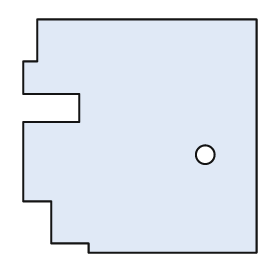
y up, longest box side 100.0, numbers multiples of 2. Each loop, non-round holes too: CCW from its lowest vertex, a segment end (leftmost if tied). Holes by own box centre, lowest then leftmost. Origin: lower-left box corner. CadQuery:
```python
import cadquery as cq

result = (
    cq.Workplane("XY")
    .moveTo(28.0, 0.0)
    .lineTo(100.0, 0.0)
    .lineTo(100.0, 100.0)
    .lineTo(6.0, 100.0)
    .lineTo(6.0, 82.0)
    .lineTo(0.0, 82.0)
    .lineTo(0.0, 68.0)
    .lineTo(24.0, 68.0)
    .lineTo(24.0, 56.0)
    .lineTo(0.0, 56.0)
    .lineTo(0.0, 22.0)
    .lineTo(12.0, 22.0)
    .lineTo(12.0, 4.0)
    .lineTo(28.0, 4.0)
    .close()
    .moveTo(78.0, 42.0)
    .circle(4.0)
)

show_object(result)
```